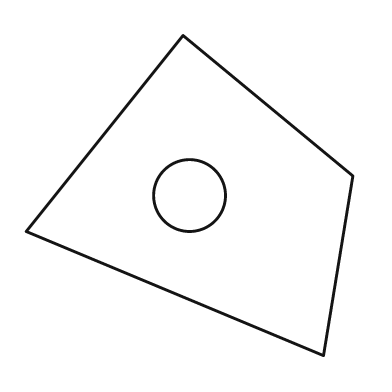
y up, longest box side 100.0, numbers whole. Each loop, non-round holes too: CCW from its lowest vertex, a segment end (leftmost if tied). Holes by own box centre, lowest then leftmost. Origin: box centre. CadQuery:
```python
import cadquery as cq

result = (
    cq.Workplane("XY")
    .moveTo(41.0, -49.0)
    .lineTo(50.0, 6.0)
    .lineTo(-2.0, 49.0)
    .lineTo(-50.0, -11.0)
    .close()
    .moveTo(0.0, 0.0)
    .circle(11.0)
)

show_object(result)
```